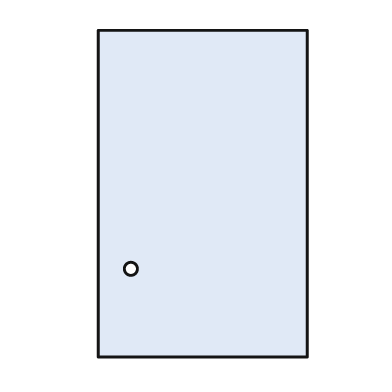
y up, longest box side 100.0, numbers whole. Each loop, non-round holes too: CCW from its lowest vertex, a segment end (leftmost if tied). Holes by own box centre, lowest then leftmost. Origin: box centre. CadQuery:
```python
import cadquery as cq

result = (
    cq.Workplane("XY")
    .moveTo(-32.0, -50.0)
    .lineTo(32.0, -50.0)
    .lineTo(32.0, 50.0)
    .lineTo(-32.0, 50.0)
    .close()
    .moveTo(-22.0, -23.0)
    .circle(2.0)
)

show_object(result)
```